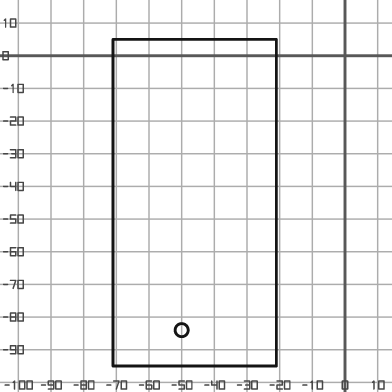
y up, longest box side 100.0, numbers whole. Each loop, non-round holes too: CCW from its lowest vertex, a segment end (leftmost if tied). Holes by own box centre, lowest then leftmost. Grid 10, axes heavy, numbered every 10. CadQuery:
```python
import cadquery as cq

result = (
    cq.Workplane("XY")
    .moveTo(-71.0, -95.0)
    .lineTo(-21.0, -95.0)
    .lineTo(-21.0, 5.0)
    .lineTo(-71.0, 5.0)
    .close()
    .moveTo(-50.0, -84.0)
    .circle(2.0)
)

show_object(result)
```